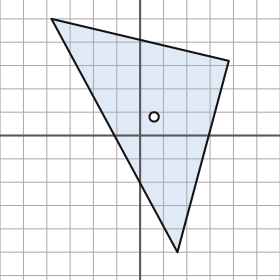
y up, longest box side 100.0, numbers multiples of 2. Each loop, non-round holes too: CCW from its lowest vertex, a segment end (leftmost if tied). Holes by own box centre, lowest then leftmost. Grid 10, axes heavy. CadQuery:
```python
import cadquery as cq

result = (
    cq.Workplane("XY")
    .moveTo(16.0, -50.0)
    .lineTo(38.0, 32.0)
    .lineTo(-38.0, 50.0)
    .close()
    .moveTo(6.0, 8.0)
    .circle(2.0)
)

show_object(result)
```